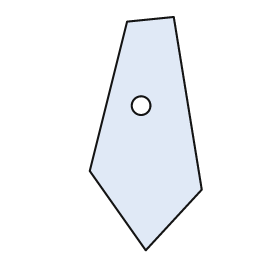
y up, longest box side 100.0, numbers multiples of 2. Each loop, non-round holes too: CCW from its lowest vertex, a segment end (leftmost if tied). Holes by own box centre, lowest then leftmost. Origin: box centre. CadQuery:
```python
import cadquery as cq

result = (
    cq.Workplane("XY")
    .moveTo(0.0, -50.0)
    .lineTo(24.0, -24.0)
    .lineTo(12.0, 50.0)
    .lineTo(-8.0, 48.0)
    .lineTo(-24.0, -16.0)
    .close()
    .moveTo(-2.0, 12.0)
    .circle(4.0)
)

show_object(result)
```